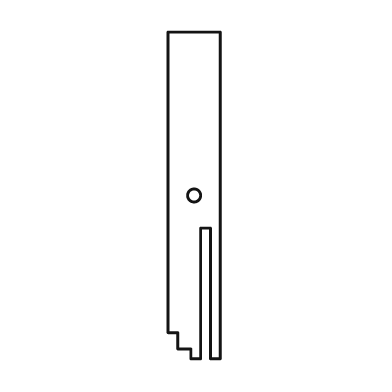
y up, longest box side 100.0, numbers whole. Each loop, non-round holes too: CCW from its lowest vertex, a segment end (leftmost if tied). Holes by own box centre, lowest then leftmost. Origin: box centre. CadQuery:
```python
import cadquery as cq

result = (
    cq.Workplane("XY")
    .moveTo(-1.0, -50.0)
    .lineTo(2.0, -50.0)
    .lineTo(2.0, -10.0)
    .lineTo(5.0, -10.0)
    .lineTo(5.0, -50.0)
    .lineTo(8.0, -50.0)
    .lineTo(8.0, 50.0)
    .lineTo(-8.0, 50.0)
    .lineTo(-8.0, -42.0)
    .lineTo(-5.0, -42.0)
    .lineTo(-5.0, -47.0)
    .lineTo(-1.0, -47.0)
    .close()
    .moveTo(0.0, 0.0)
    .circle(2.0)
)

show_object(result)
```